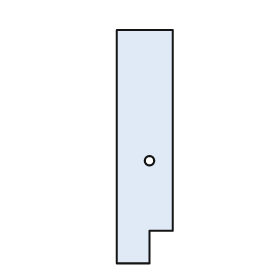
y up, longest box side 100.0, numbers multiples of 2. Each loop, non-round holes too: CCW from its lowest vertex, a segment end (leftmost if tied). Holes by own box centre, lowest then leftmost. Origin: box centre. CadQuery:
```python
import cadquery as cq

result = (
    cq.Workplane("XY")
    .moveTo(-12.0, -50.0)
    .lineTo(2.0, -50.0)
    .lineTo(2.0, -36.0)
    .lineTo(12.0, -36.0)
    .lineTo(12.0, 50.0)
    .lineTo(-12.0, 50.0)
    .close()
    .moveTo(2.0, -6.0)
    .circle(2.0)
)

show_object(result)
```